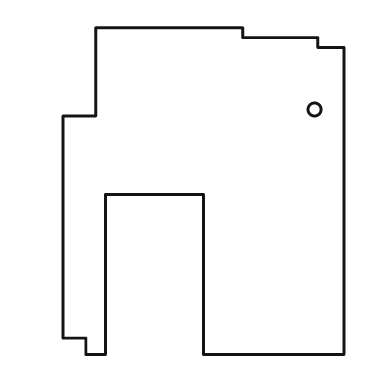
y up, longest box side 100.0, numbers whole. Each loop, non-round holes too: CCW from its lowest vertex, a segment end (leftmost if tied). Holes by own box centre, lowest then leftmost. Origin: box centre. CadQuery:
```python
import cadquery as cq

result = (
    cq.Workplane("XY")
    .moveTo(-36.0, -50.0)
    .lineTo(-30.0, -50.0)
    .lineTo(-30.0, -1.0)
    .lineTo(0.0, -1.0)
    .lineTo(0.0, -50.0)
    .lineTo(43.0, -50.0)
    .lineTo(43.0, 44.0)
    .lineTo(35.0, 44.0)
    .lineTo(35.0, 47.0)
    .lineTo(12.0, 47.0)
    .lineTo(12.0, 50.0)
    .lineTo(-33.0, 50.0)
    .lineTo(-33.0, 23.0)
    .lineTo(-43.0, 23.0)
    .lineTo(-43.0, -45.0)
    .lineTo(-36.0, -45.0)
    .close()
    .moveTo(34.0, 25.0)
    .circle(2.0)
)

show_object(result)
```